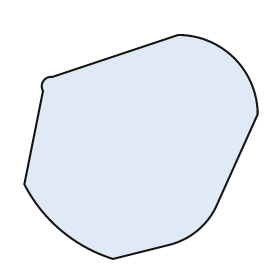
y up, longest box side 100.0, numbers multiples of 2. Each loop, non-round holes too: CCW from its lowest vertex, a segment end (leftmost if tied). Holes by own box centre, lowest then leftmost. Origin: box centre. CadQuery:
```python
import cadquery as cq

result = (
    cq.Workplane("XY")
    .moveTo(-12.0, -48.0)
    .lineTo(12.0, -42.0)
    .threePointArc((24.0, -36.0), (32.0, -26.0))
    .lineTo(50.0, 14.0)
    .threePointArc((40.0, 38.0), (16.0, 48.0))
    .lineTo(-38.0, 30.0)
    .threePointArc((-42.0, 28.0), (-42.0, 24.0))
    .lineTo(-50.0, -16.0)
    .threePointArc((-34.0, -36.0), (-12.0, -48.0))
    .close()
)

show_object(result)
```